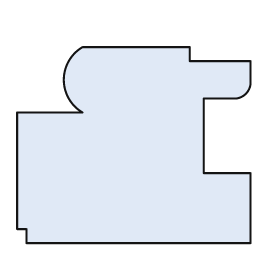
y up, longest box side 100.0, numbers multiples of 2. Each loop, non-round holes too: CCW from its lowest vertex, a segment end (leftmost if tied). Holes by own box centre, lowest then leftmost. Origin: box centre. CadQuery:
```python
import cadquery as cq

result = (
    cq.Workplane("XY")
    .moveTo(-46.0, -42.0)
    .lineTo(50.0, -42.0)
    .lineTo(50.0, -12.0)
    .lineTo(30.0, -12.0)
    .lineTo(30.0, 20.0)
    .lineTo(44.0, 20.0)
    .threePointArc((48.0, 22.0), (50.0, 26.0))
    .lineTo(50.0, 36.0)
    .lineTo(24.0, 36.0)
    .lineTo(24.0, 42.0)
    .lineTo(-22.0, 42.0)
    .threePointArc((-30.0, 28.0), (-22.0, 14.0))
    .lineTo(-50.0, 14.0)
    .lineTo(-50.0, -36.0)
    .lineTo(-46.0, -36.0)
    .close()
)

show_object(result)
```